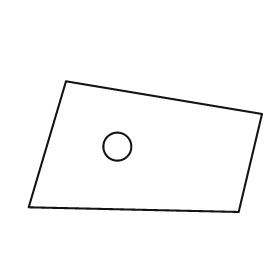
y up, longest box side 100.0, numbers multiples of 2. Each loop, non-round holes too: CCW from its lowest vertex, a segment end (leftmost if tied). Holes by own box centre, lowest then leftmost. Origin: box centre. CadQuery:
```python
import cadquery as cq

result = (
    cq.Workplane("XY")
    .moveTo(40.0, -28.0)
    .lineTo(50.0, 14.0)
    .lineTo(-34.0, 28.0)
    .lineTo(-50.0, -26.0)
    .close()
    .moveTo(-12.0, 0.0)
    .circle(6.0)
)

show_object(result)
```